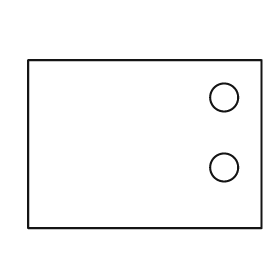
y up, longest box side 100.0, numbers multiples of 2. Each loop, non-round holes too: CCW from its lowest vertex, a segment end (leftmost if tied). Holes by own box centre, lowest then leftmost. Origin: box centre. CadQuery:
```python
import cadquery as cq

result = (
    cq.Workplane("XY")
    .moveTo(-50.0, -36.0)
    .lineTo(50.0, -36.0)
    .lineTo(50.0, 36.0)
    .lineTo(-50.0, 36.0)
    .close()
    .moveTo(34.0, -10.0)
    .circle(6.0)
    .moveTo(34.0, 20.0)
    .circle(6.0)
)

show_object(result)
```